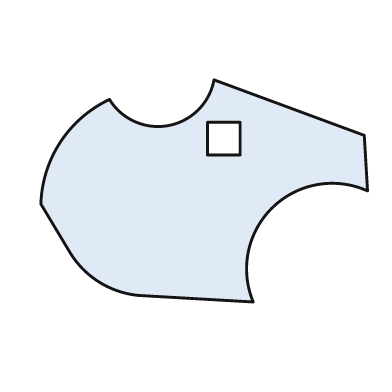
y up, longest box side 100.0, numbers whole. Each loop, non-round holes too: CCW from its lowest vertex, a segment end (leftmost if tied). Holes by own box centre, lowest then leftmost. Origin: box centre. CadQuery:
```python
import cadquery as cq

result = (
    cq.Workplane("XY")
    .moveTo(15.0, -34.0)
    .threePointArc((21.0, -5.0), (50.0, 0.0))
    .lineTo(49.0, 17.0)
    .lineTo(3.0, 34.0)
    .threePointArc((-11.0, 20.0), (-29.0, 28.0))
    .threePointArc((-44.0, 15.0), (-50.0, -4.0))
    .lineTo(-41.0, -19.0)
    .threePointArc((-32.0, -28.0), (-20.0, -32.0))
    .close()
    .moveTo(1.0, 11.0)
    .lineTo(11.0, 11.0)
    .lineTo(11.0, 21.0)
    .lineTo(1.0, 21.0)
    .close()
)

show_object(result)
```